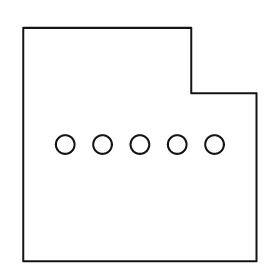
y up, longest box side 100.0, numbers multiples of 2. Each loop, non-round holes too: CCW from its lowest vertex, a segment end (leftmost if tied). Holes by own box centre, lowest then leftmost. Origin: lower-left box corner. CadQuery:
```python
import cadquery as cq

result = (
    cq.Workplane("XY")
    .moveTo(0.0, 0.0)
    .lineTo(100.0, 0.0)
    .lineTo(100.0, 72.0)
    .lineTo(72.0, 72.0)
    .lineTo(72.0, 100.0)
    .lineTo(0.0, 100.0)
    .close()
    .moveTo(18.0, 50.0)
    .circle(4.0)
    .moveTo(34.0, 50.0)
    .circle(4.0)
    .moveTo(50.0, 50.0)
    .circle(4.0)
    .moveTo(66.0, 50.0)
    .circle(4.0)
    .moveTo(82.0, 50.0)
    .circle(4.0)
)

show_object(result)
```